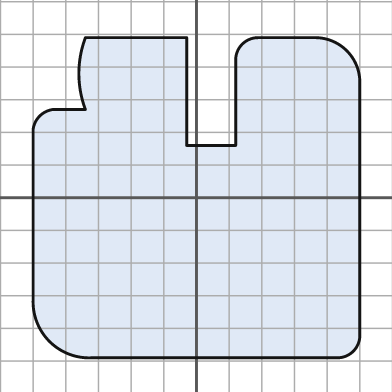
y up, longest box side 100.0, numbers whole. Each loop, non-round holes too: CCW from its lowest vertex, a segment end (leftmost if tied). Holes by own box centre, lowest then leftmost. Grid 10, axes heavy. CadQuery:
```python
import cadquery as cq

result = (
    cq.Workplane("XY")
    .moveTo(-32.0, -49.0)
    .lineTo(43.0, -49.0)
    .threePointArc((48.0, -47.0), (50.0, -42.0))
    .lineTo(50.0, 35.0)
    .threePointArc((46.0, 45.0), (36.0, 49.0))
    .lineTo(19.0, 49.0)
    .threePointArc((14.0, 47.0), (12.0, 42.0))
    .lineTo(12.0, 16.0)
    .lineTo(-3.0, 16.0)
    .lineTo(-3.0, 49.0)
    .lineTo(-34.0, 49.0)
    .threePointArc((-36.0, 38.0), (-34.0, 27.0))
    .lineTo(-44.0, 27.0)
    .threePointArc((-48.0, 25.0), (-50.0, 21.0))
    .lineTo(-50.0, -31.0)
    .threePointArc((-45.0, -44.0), (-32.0, -49.0))
    .close()
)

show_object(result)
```